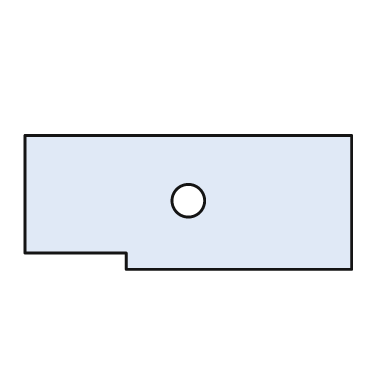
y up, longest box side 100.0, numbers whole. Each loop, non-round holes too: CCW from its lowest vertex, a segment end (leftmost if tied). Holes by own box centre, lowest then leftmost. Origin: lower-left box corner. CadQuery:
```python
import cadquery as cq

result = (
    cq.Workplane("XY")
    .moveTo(31.0, 0.0)
    .lineTo(100.0, 0.0)
    .lineTo(100.0, 41.0)
    .lineTo(0.0, 41.0)
    .lineTo(0.0, 5.0)
    .lineTo(31.0, 5.0)
    .close()
    .moveTo(50.0, 21.0)
    .circle(5.0)
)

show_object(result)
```